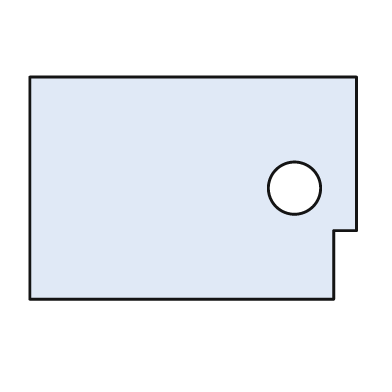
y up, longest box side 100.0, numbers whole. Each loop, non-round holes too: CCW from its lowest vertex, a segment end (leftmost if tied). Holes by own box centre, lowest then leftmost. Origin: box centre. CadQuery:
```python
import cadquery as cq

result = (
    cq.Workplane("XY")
    .moveTo(-50.0, -34.0)
    .lineTo(43.0, -34.0)
    .lineTo(43.0, -13.0)
    .lineTo(50.0, -13.0)
    .lineTo(50.0, 34.0)
    .lineTo(-50.0, 34.0)
    .close()
    .moveTo(31.0, 0.0)
    .circle(8.0)
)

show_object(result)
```